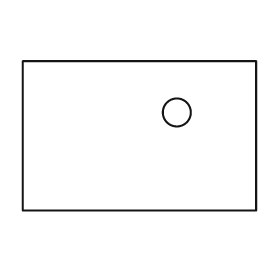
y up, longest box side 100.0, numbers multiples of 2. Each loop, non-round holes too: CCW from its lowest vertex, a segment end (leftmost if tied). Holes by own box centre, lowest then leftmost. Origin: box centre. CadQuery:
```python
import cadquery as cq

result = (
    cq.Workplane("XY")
    .moveTo(-50.0, -32.0)
    .lineTo(50.0, -32.0)
    .lineTo(50.0, 32.0)
    .lineTo(-50.0, 32.0)
    .close()
    .moveTo(16.0, 10.0)
    .circle(6.0)
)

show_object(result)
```